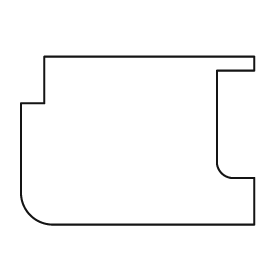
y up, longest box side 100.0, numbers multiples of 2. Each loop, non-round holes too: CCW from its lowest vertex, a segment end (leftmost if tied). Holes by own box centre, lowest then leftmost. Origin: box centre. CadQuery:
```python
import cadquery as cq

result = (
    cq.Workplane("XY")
    .moveTo(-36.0, -36.0)
    .lineTo(50.0, -36.0)
    .lineTo(50.0, -16.0)
    .lineTo(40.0, -16.0)
    .threePointArc((36.0, -14.0), (34.0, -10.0))
    .lineTo(34.0, 30.0)
    .lineTo(50.0, 30.0)
    .lineTo(50.0, 36.0)
    .lineTo(-40.0, 36.0)
    .lineTo(-40.0, 16.0)
    .lineTo(-50.0, 16.0)
    .lineTo(-50.0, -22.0)
    .threePointArc((-46.0, -32.0), (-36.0, -36.0))
    .close()
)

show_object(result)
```